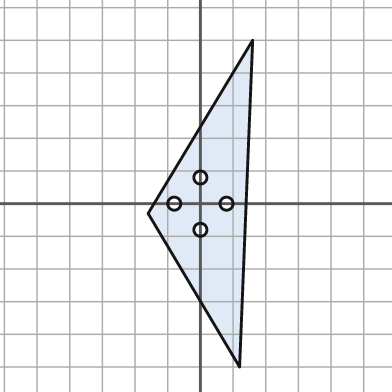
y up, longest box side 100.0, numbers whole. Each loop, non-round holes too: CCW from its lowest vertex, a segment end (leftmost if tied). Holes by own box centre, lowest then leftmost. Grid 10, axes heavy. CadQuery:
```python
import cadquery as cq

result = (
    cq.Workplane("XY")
    .moveTo(12.0, -50.0)
    .lineTo(16.0, 50.0)
    .lineTo(-16.0, -3.0)
    .close()
    .moveTo(0.0, -8.0)
    .circle(2.0)
    .moveTo(-8.0, 0.0)
    .circle(2.0)
    .moveTo(8.0, 0.0)
    .circle(2.0)
    .moveTo(0.0, 8.0)
    .circle(2.0)
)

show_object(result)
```